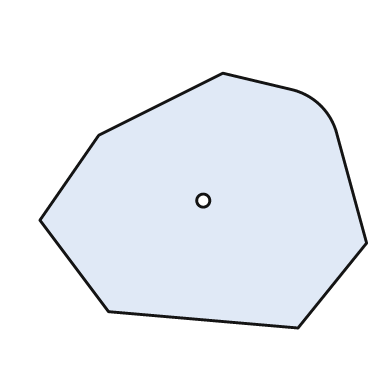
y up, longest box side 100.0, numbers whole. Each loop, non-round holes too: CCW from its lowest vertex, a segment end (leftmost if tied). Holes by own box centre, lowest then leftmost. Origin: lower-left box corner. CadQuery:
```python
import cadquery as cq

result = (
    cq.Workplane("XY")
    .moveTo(79.0, 0.0)
    .lineTo(100.0, 26.0)
    .lineTo(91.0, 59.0)
    .threePointArc((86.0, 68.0), (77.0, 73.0))
    .lineTo(56.0, 78.0)
    .lineTo(18.0, 59.0)
    .lineTo(0.0, 33.0)
    .lineTo(21.0, 5.0)
    .close()
    .moveTo(50.0, 39.0)
    .circle(2.0)
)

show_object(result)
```